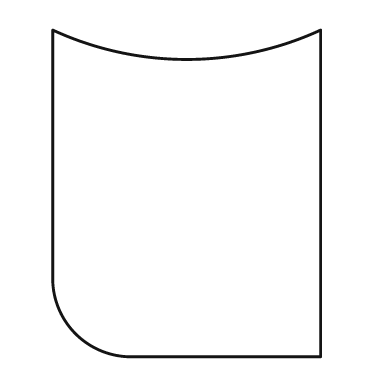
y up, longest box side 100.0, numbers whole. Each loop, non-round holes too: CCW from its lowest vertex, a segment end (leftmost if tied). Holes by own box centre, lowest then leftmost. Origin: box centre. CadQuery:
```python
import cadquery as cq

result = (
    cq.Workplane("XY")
    .moveTo(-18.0, -50.0)
    .lineTo(41.0, -50.0)
    .lineTo(41.0, 50.0)
    .threePointArc((0.0, 41.0), (-41.0, 50.0))
    .lineTo(-41.0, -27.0)
    .threePointArc((-34.0, -43.0), (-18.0, -50.0))
    .close()
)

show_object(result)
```